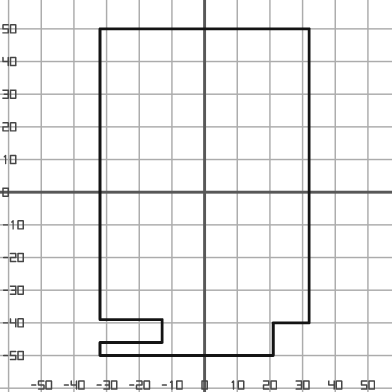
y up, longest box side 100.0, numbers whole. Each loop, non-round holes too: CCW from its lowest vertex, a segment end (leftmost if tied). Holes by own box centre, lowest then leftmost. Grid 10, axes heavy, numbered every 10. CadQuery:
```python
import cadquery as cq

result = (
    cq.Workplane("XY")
    .moveTo(-32.0, -50.0)
    .lineTo(21.0, -50.0)
    .lineTo(21.0, -40.0)
    .lineTo(32.0, -40.0)
    .lineTo(32.0, 50.0)
    .lineTo(-32.0, 50.0)
    .lineTo(-32.0, -39.0)
    .lineTo(-13.0, -39.0)
    .lineTo(-13.0, -46.0)
    .lineTo(-32.0, -46.0)
    .close()
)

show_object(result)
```